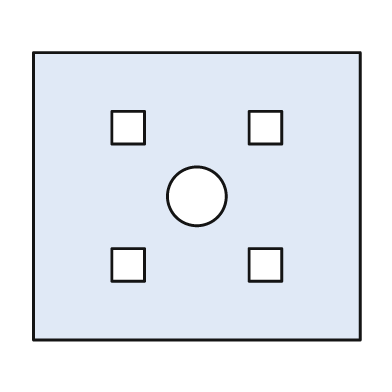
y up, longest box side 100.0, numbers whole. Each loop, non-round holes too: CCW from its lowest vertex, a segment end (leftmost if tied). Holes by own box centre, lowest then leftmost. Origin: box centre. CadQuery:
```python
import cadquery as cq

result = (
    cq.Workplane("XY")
    .moveTo(-50.0, -44.0)
    .lineTo(50.0, -44.0)
    .lineTo(50.0, 44.0)
    .lineTo(-50.0, 44.0)
    .close()
    .moveTo(-26.0, -26.0)
    .lineTo(-16.0, -26.0)
    .lineTo(-16.0, -16.0)
    .lineTo(-26.0, -16.0)
    .close()
    .moveTo(16.0, -26.0)
    .lineTo(26.0, -26.0)
    .lineTo(26.0, -16.0)
    .lineTo(16.0, -16.0)
    .close()
    .moveTo(0.0, 0.0)
    .circle(9.0)
    .moveTo(-26.0, 16.0)
    .lineTo(-16.0, 16.0)
    .lineTo(-16.0, 26.0)
    .lineTo(-26.0, 26.0)
    .close()
    .moveTo(16.0, 16.0)
    .lineTo(26.0, 16.0)
    .lineTo(26.0, 26.0)
    .lineTo(16.0, 26.0)
    .close()
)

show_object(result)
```